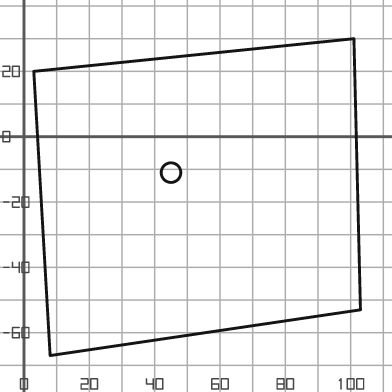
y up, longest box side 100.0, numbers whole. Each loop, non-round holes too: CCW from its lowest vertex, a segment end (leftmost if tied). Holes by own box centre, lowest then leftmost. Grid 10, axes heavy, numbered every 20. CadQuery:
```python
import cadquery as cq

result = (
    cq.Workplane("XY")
    .moveTo(8.0, -67.0)
    .lineTo(103.0, -53.0)
    .lineTo(101.0, 30.0)
    .lineTo(3.0, 20.0)
    .close()
    .moveTo(45.0, -11.0)
    .circle(3.0)
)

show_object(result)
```